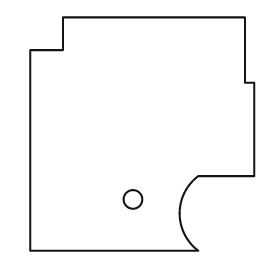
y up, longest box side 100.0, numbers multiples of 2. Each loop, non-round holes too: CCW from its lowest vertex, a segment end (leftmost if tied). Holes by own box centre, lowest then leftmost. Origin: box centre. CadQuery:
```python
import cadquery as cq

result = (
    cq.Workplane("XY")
    .moveTo(-48.0, -50.0)
    .lineTo(24.0, -50.0)
    .threePointArc((16.0, -34.0), (24.0, -18.0))
    .lineTo(48.0, -18.0)
    .lineTo(48.0, 22.0)
    .lineTo(44.0, 22.0)
    .lineTo(44.0, 50.0)
    .lineTo(-34.0, 50.0)
    .lineTo(-34.0, 36.0)
    .lineTo(-48.0, 36.0)
    .close()
    .moveTo(-4.0, -28.0)
    .circle(4.0)
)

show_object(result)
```